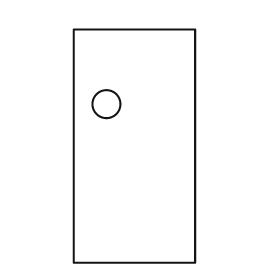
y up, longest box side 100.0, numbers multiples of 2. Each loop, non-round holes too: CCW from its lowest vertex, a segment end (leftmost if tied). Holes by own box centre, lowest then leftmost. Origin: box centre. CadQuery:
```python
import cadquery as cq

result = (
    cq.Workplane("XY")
    .moveTo(-26.0, -50.0)
    .lineTo(26.0, -50.0)
    .lineTo(26.0, 50.0)
    .lineTo(-26.0, 50.0)
    .close()
    .moveTo(-12.0, 18.0)
    .circle(6.0)
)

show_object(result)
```